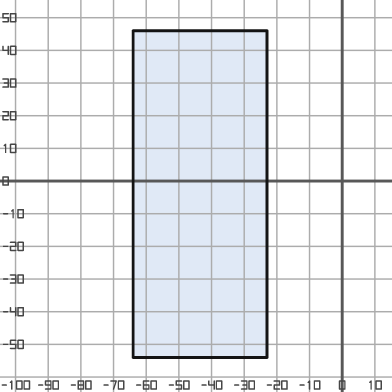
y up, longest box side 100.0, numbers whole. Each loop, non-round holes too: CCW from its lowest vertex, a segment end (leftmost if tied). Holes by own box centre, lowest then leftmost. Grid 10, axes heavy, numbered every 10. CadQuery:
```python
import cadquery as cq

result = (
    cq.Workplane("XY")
    .moveTo(-64.0, -54.0)
    .lineTo(-23.0, -54.0)
    .lineTo(-23.0, 46.0)
    .lineTo(-64.0, 46.0)
    .close()
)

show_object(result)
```